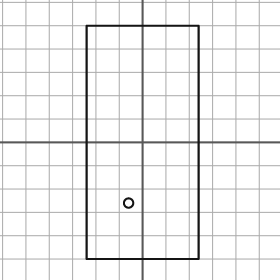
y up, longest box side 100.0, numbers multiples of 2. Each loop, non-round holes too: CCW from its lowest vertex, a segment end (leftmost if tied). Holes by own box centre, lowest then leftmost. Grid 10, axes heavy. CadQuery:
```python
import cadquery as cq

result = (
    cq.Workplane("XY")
    .moveTo(-24.0, -50.0)
    .lineTo(24.0, -50.0)
    .lineTo(24.0, 50.0)
    .lineTo(-24.0, 50.0)
    .close()
    .moveTo(-6.0, -26.0)
    .circle(2.0)
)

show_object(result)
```